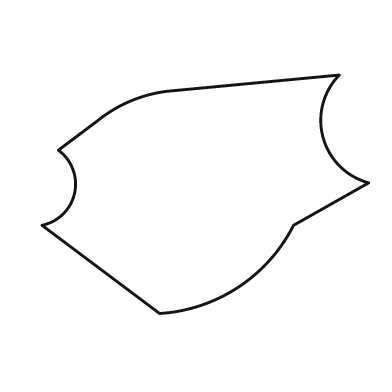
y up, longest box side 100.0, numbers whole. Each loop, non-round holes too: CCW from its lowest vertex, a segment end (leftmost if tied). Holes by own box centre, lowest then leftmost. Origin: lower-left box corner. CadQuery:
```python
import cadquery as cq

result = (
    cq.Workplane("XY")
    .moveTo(36.0, 0.0)
    .threePointArc((60.0, 8.0), (77.0, 27.0))
    .lineTo(100.0, 40.0)
    .threePointArc((86.0, 54.0), (91.0, 73.0))
    .lineTo(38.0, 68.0)
    .threePointArc((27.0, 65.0), (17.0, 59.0))
    .lineTo(5.0, 50.0)
    .threePointArc((10.0, 37.0), (0.0, 27.0))
    .close()
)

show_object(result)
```